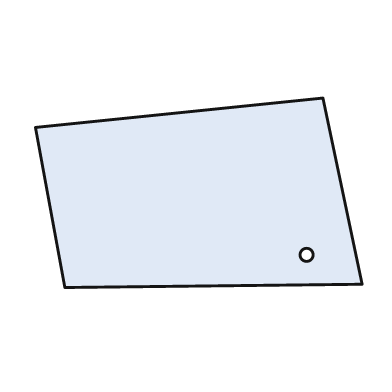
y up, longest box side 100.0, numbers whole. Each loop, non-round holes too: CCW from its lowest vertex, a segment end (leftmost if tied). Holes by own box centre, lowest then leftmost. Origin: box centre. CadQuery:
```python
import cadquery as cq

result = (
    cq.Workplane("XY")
    .moveTo(-41.0, -29.0)
    .lineTo(50.0, -28.0)
    .lineTo(38.0, 29.0)
    .lineTo(-50.0, 20.0)
    .close()
    .moveTo(33.0, -19.0)
    .circle(2.0)
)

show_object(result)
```